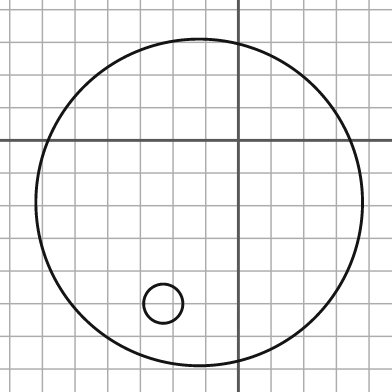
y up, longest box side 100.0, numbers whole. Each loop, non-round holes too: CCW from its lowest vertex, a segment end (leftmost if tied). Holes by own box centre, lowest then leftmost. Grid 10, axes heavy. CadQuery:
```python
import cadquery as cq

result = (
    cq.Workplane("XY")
    .moveTo(-12.0, -19.0)
    .circle(50.0)
    .moveTo(-23.0, -50.0)
    .circle(6.0)
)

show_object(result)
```